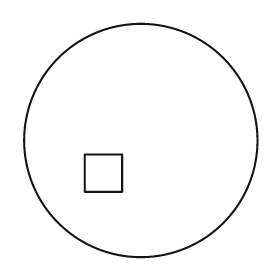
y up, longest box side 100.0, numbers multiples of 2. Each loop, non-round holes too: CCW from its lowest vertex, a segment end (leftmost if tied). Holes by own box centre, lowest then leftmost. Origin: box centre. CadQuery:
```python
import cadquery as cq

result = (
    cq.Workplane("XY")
    .moveTo(0.0, 0.0)
    .circle(50.0)
    .moveTo(-24.0, -22.0)
    .lineTo(-8.0, -22.0)
    .lineTo(-8.0, -6.0)
    .lineTo(-24.0, -6.0)
    .close()
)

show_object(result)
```